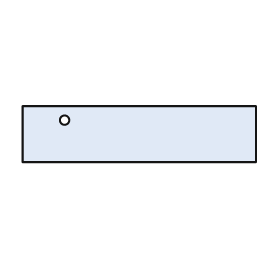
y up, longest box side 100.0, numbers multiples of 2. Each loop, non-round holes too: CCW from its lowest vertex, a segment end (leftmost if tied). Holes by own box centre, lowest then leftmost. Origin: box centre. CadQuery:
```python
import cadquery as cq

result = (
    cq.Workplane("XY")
    .moveTo(-50.0, -12.0)
    .lineTo(50.0, -12.0)
    .lineTo(50.0, 12.0)
    .lineTo(-50.0, 12.0)
    .close()
    .moveTo(-32.0, 6.0)
    .circle(2.0)
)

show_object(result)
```